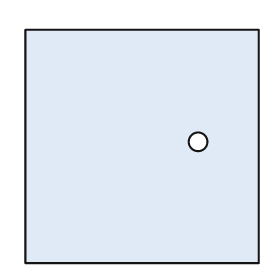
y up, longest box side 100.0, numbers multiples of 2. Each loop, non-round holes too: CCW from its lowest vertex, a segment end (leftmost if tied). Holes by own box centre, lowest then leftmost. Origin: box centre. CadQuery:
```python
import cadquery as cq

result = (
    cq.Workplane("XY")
    .moveTo(-50.0, -50.0)
    .lineTo(50.0, -50.0)
    .lineTo(50.0, 50.0)
    .lineTo(-50.0, 50.0)
    .close()
    .moveTo(24.0, 2.0)
    .circle(4.0)
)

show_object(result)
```